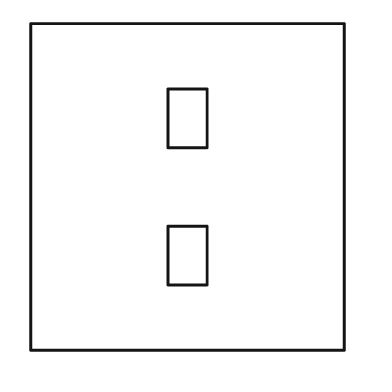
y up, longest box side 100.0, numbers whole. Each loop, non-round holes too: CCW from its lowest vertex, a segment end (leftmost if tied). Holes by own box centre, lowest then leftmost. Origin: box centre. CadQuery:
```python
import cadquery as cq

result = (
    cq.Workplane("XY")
    .moveTo(-48.0, -50.0)
    .lineTo(48.0, -50.0)
    .lineTo(48.0, 50.0)
    .lineTo(-48.0, 50.0)
    .close()
    .moveTo(-6.0, -30.0)
    .lineTo(6.0, -30.0)
    .lineTo(6.0, -12.0)
    .lineTo(-6.0, -12.0)
    .close()
    .moveTo(-6.0, 12.0)
    .lineTo(6.0, 12.0)
    .lineTo(6.0, 30.0)
    .lineTo(-6.0, 30.0)
    .close()
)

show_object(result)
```